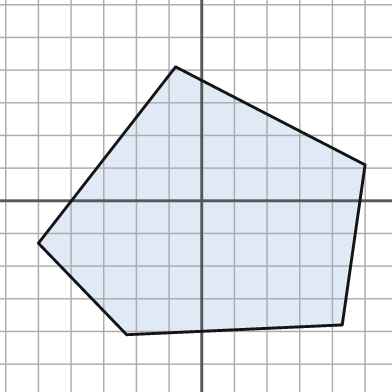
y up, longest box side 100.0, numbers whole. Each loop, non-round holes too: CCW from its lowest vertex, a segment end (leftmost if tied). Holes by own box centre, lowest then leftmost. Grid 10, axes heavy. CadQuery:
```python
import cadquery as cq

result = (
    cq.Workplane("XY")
    .moveTo(-23.0, -41.0)
    .lineTo(43.0, -38.0)
    .lineTo(50.0, 11.0)
    .lineTo(-8.0, 41.0)
    .lineTo(-50.0, -13.0)
    .close()
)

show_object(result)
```